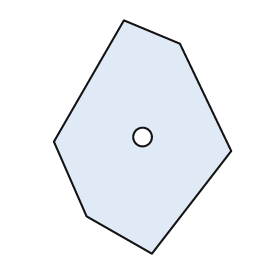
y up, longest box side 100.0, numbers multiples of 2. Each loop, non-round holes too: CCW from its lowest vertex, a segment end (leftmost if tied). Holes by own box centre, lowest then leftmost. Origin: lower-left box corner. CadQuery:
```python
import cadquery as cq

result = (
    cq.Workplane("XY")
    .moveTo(42.0, 0.0)
    .lineTo(76.0, 44.0)
    .lineTo(54.0, 90.0)
    .lineTo(30.0, 100.0)
    .lineTo(0.0, 48.0)
    .lineTo(14.0, 16.0)
    .close()
    .moveTo(38.0, 50.0)
    .circle(4.0)
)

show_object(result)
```